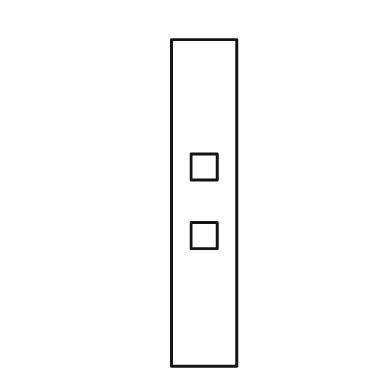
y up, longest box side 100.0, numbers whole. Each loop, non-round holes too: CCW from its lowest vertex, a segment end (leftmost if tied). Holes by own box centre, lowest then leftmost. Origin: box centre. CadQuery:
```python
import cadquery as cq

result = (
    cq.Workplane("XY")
    .moveTo(-10.0, -50.0)
    .lineTo(10.0, -50.0)
    .lineTo(10.0, 50.0)
    .lineTo(-10.0, 50.0)
    .close()
    .moveTo(-4.0, -14.0)
    .lineTo(4.0, -14.0)
    .lineTo(4.0, -6.0)
    .lineTo(-4.0, -6.0)
    .close()
    .moveTo(-4.0, 7.0)
    .lineTo(4.0, 7.0)
    .lineTo(4.0, 15.0)
    .lineTo(-4.0, 15.0)
    .close()
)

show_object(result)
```